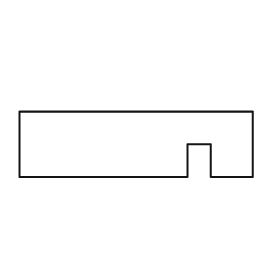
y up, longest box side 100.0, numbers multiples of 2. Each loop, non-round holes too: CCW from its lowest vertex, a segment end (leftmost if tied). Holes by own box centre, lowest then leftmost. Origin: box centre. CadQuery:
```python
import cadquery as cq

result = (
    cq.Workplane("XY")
    .moveTo(-50.0, -14.0)
    .lineTo(22.0, -14.0)
    .lineTo(22.0, 0.0)
    .lineTo(32.0, 0.0)
    .lineTo(32.0, -14.0)
    .lineTo(50.0, -14.0)
    .lineTo(50.0, 14.0)
    .lineTo(-50.0, 14.0)
    .close()
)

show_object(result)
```